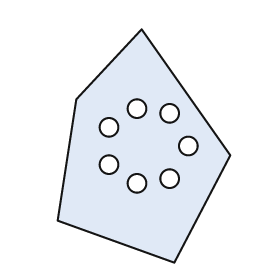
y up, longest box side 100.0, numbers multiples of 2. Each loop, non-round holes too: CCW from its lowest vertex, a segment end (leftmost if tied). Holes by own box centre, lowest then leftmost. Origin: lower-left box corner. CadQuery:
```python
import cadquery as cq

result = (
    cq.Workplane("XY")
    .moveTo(50.0, 0.0)
    .lineTo(74.0, 46.0)
    .lineTo(36.0, 100.0)
    .lineTo(8.0, 70.0)
    .lineTo(0.0, 18.0)
    .close()
    .moveTo(34.0, 34.0)
    .circle(4.0)
    .moveTo(48.0, 36.0)
    .circle(4.0)
    .moveTo(22.0, 42.0)
    .circle(4.0)
    .moveTo(56.0, 50.0)
    .circle(4.0)
    .moveTo(22.0, 58.0)
    .circle(4.0)
    .moveTo(48.0, 64.0)
    .circle(4.0)
    .moveTo(34.0, 66.0)
    .circle(4.0)
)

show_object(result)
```